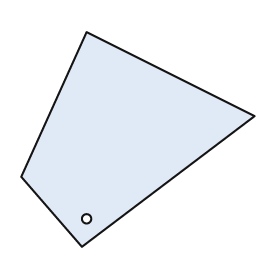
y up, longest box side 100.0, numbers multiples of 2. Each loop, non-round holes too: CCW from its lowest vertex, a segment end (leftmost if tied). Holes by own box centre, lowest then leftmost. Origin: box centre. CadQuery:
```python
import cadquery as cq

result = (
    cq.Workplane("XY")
    .moveTo(-24.0, -46.0)
    .lineTo(50.0, 10.0)
    .lineTo(-22.0, 46.0)
    .lineTo(-50.0, -16.0)
    .close()
    .moveTo(-22.0, -34.0)
    .circle(2.0)
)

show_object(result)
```